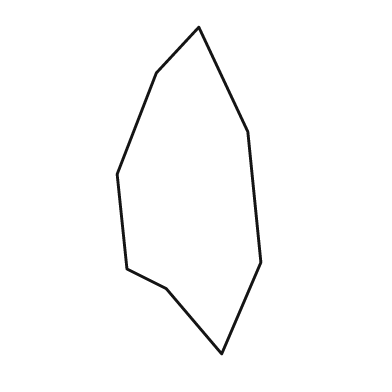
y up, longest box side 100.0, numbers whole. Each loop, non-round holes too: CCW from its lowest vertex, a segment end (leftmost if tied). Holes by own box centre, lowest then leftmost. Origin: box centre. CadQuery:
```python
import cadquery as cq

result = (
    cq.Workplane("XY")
    .moveTo(10.0, -50.0)
    .lineTo(22.0, -22.0)
    .lineTo(18.0, 18.0)
    .lineTo(3.0, 50.0)
    .lineTo(-10.0, 36.0)
    .lineTo(-22.0, 5.0)
    .lineTo(-19.0, -24.0)
    .lineTo(-7.0, -30.0)
    .close()
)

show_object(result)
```